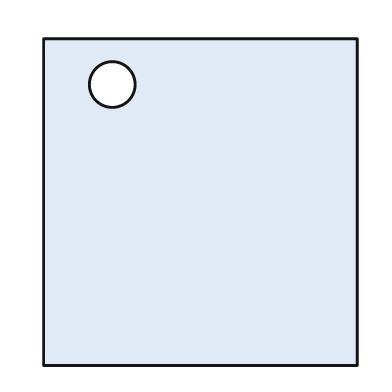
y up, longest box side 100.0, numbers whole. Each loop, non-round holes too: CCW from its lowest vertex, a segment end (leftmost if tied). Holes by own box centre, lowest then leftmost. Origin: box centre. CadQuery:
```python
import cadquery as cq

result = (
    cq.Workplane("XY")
    .moveTo(-48.0, -50.0)
    .lineTo(48.0, -50.0)
    .lineTo(48.0, 50.0)
    .lineTo(-48.0, 50.0)
    .close()
    .moveTo(-27.0, 36.0)
    .circle(7.0)
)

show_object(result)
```